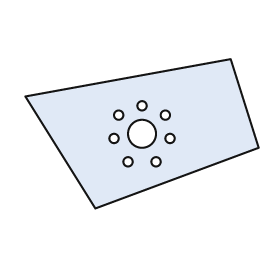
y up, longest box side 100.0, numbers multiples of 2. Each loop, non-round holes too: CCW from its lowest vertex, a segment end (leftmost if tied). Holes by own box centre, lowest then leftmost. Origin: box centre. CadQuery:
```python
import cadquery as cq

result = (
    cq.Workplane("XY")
    .moveTo(-20.0, -32.0)
    .lineTo(50.0, -6.0)
    .lineTo(38.0, 32.0)
    .lineTo(-50.0, 16.0)
    .close()
    .moveTo(-6.0, -12.0)
    .circle(2.0)
    .moveTo(6.0, -12.0)
    .circle(2.0)
    .moveTo(-12.0, -2.0)
    .circle(2.0)
    .moveTo(12.0, -2.0)
    .circle(2.0)
    .moveTo(0.0, 0.0)
    .circle(6.0)
    .moveTo(-10.0, 8.0)
    .circle(2.0)
    .moveTo(10.0, 8.0)
    .circle(2.0)
    .moveTo(0.0, 12.0)
    .circle(2.0)
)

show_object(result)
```